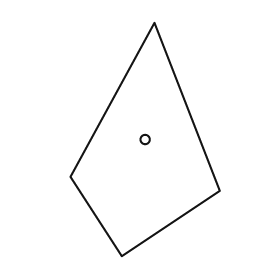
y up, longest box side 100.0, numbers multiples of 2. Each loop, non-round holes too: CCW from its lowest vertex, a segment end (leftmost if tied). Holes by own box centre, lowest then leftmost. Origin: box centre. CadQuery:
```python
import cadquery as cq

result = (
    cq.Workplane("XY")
    .moveTo(-10.0, -50.0)
    .lineTo(32.0, -22.0)
    .lineTo(4.0, 50.0)
    .lineTo(-32.0, -16.0)
    .close()
    .moveTo(0.0, 0.0)
    .circle(2.0)
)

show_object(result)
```